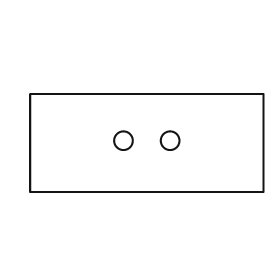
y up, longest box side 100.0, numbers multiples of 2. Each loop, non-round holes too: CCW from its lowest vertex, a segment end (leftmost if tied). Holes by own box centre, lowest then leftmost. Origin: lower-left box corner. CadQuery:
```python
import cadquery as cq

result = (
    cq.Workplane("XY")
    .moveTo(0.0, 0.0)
    .lineTo(100.0, 0.0)
    .lineTo(100.0, 42.0)
    .lineTo(0.0, 42.0)
    .close()
    .moveTo(40.0, 22.0)
    .circle(4.0)
    .moveTo(60.0, 22.0)
    .circle(4.0)
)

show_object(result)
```